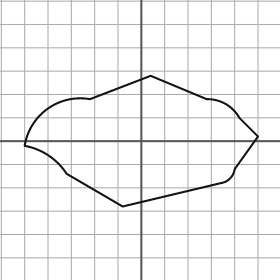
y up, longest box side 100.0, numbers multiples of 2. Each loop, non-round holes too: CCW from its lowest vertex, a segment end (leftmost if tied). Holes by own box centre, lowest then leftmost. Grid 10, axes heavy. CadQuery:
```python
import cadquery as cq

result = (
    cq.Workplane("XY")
    .moveTo(-8.0, -28.0)
    .lineTo(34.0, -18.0)
    .threePointArc((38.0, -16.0), (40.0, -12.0))
    .lineTo(50.0, 2.0)
    .lineTo(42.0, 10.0)
    .threePointArc((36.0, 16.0), (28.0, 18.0))
    .lineTo(4.0, 28.0)
    .lineTo(-22.0, 18.0)
    .threePointArc((-40.0, 14.0), (-50.0, -2.0))
    .threePointArc((-40.0, -6.0), (-32.0, -14.0))
    .close()
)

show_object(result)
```